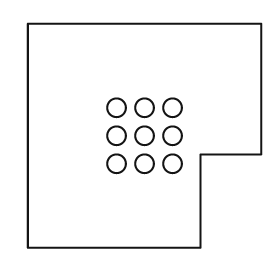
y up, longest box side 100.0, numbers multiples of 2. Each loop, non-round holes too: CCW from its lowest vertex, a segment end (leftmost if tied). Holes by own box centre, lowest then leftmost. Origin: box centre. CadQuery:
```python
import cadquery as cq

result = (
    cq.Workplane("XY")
    .moveTo(-50.0, -48.0)
    .lineTo(24.0, -48.0)
    .lineTo(24.0, -8.0)
    .lineTo(50.0, -8.0)
    .lineTo(50.0, 48.0)
    .lineTo(-50.0, 48.0)
    .close()
    .moveTo(-12.0, -12.0)
    .circle(4.0)
    .moveTo(0.0, -12.0)
    .circle(4.0)
    .moveTo(12.0, -12.0)
    .circle(4.0)
    .moveTo(-12.0, 0.0)
    .circle(4.0)
    .moveTo(0.0, 0.0)
    .circle(4.0)
    .moveTo(12.0, 0.0)
    .circle(4.0)
    .moveTo(-12.0, 12.0)
    .circle(4.0)
    .moveTo(0.0, 12.0)
    .circle(4.0)
    .moveTo(12.0, 12.0)
    .circle(4.0)
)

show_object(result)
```